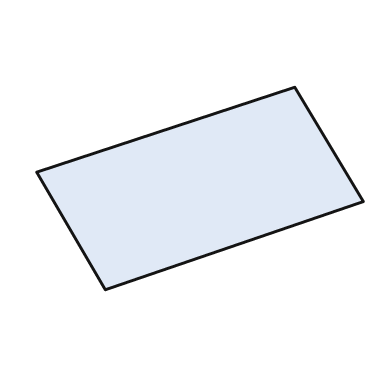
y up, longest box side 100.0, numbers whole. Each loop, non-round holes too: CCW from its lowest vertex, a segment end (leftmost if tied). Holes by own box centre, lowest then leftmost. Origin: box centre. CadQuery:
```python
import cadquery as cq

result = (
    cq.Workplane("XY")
    .moveTo(-29.0, -31.0)
    .lineTo(50.0, -4.0)
    .lineTo(29.0, 31.0)
    .lineTo(-50.0, 5.0)
    .close()
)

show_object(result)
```